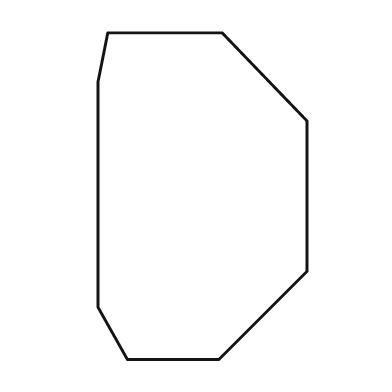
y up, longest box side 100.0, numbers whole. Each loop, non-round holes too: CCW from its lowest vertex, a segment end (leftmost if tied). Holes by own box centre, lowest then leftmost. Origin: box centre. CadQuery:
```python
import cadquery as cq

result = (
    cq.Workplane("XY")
    .moveTo(-23.0, -50.0)
    .lineTo(5.0, -50.0)
    .lineTo(32.0, -23.0)
    .lineTo(32.0, 23.0)
    .lineTo(6.0, 50.0)
    .lineTo(-29.0, 50.0)
    .lineTo(-32.0, 35.0)
    .lineTo(-32.0, -34.0)
    .close()
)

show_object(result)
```